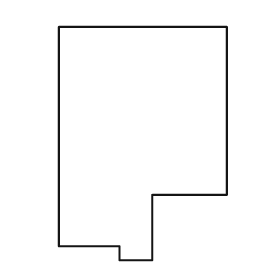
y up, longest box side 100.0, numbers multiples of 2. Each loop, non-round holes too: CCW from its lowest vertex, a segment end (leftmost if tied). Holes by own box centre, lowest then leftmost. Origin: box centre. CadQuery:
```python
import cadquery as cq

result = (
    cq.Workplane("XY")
    .moveTo(-10.0, -50.0)
    .lineTo(4.0, -50.0)
    .lineTo(4.0, -22.0)
    .lineTo(36.0, -22.0)
    .lineTo(36.0, 50.0)
    .lineTo(-36.0, 50.0)
    .lineTo(-36.0, -44.0)
    .lineTo(-10.0, -44.0)
    .close()
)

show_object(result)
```